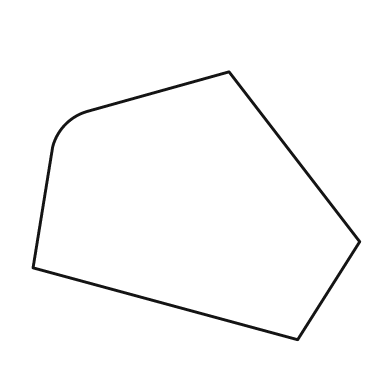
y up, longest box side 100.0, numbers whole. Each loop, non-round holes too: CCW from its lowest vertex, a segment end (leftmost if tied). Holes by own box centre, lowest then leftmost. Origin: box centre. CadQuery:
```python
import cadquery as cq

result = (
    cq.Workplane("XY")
    .moveTo(31.0, -41.0)
    .lineTo(50.0, -11.0)
    .lineTo(10.0, 41.0)
    .lineTo(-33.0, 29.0)
    .threePointArc((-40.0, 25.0), (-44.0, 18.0))
    .lineTo(-50.0, -19.0)
    .close()
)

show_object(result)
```